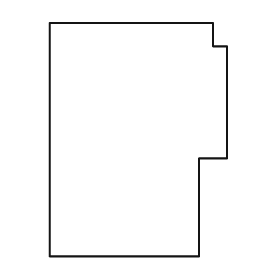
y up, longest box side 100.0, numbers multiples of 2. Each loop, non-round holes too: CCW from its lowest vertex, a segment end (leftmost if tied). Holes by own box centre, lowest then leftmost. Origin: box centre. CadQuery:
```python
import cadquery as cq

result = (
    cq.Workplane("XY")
    .moveTo(-38.0, -50.0)
    .lineTo(26.0, -50.0)
    .lineTo(26.0, -8.0)
    .lineTo(38.0, -8.0)
    .lineTo(38.0, 40.0)
    .lineTo(32.0, 40.0)
    .lineTo(32.0, 50.0)
    .lineTo(-38.0, 50.0)
    .close()
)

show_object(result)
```